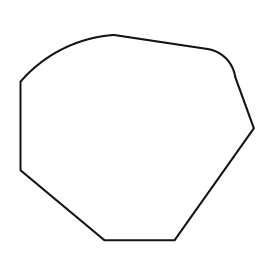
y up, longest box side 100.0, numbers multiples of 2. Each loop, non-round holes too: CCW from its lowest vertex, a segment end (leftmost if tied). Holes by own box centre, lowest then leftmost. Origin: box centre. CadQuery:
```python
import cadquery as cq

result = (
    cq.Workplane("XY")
    .moveTo(-14.0, -44.0)
    .lineTo(16.0, -44.0)
    .lineTo(50.0, 4.0)
    .lineTo(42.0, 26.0)
    .threePointArc((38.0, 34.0), (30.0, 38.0))
    .lineTo(-10.0, 44.0)
    .threePointArc((-32.0, 38.0), (-50.0, 24.0))
    .lineTo(-50.0, -14.0)
    .close()
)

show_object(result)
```